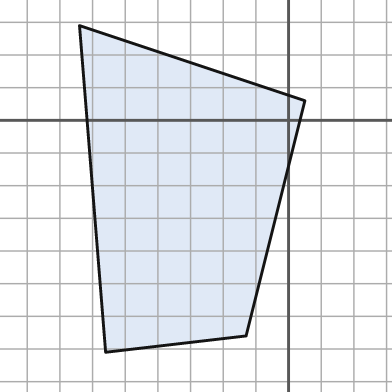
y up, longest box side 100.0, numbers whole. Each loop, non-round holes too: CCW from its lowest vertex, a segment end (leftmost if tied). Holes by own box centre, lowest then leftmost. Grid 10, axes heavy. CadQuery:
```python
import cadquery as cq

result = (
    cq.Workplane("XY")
    .moveTo(-56.0, -71.0)
    .lineTo(-13.0, -66.0)
    .lineTo(5.0, 6.0)
    .lineTo(-64.0, 29.0)
    .close()
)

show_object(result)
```